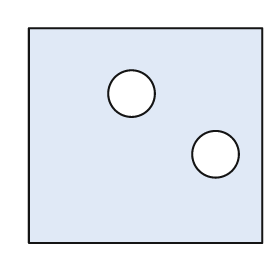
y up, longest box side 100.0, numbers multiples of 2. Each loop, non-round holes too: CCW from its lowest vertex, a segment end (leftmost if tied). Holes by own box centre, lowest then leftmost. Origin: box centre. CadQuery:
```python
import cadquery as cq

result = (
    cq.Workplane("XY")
    .moveTo(-50.0, -46.0)
    .lineTo(50.0, -46.0)
    .lineTo(50.0, 46.0)
    .lineTo(-50.0, 46.0)
    .close()
    .moveTo(30.0, -8.0)
    .circle(10.0)
    .moveTo(-6.0, 18.0)
    .circle(10.0)
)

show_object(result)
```